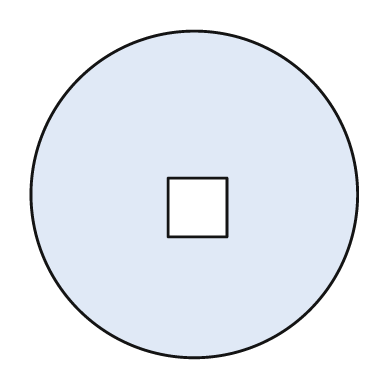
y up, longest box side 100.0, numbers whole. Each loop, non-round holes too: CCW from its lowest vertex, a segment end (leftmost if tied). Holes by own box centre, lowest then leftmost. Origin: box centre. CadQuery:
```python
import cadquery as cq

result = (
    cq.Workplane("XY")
    .moveTo(0.0, 0.0)
    .circle(50.0)
    .moveTo(-8.0, -13.0)
    .lineTo(10.0, -13.0)
    .lineTo(10.0, 5.0)
    .lineTo(-8.0, 5.0)
    .close()
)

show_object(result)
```